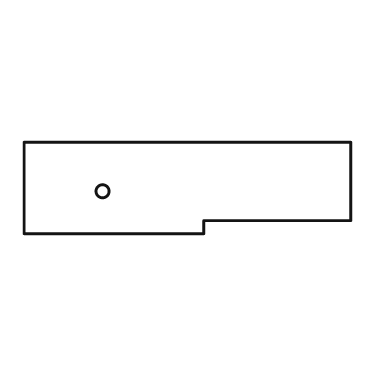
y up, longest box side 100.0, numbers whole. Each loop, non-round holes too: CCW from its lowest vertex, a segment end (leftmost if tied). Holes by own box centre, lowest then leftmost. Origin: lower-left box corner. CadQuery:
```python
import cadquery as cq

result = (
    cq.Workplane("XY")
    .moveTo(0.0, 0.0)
    .lineTo(55.0, 0.0)
    .lineTo(55.0, 4.0)
    .lineTo(100.0, 4.0)
    .lineTo(100.0, 28.0)
    .lineTo(0.0, 28.0)
    .close()
    .moveTo(24.0, 13.0)
    .circle(2.0)
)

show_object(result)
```